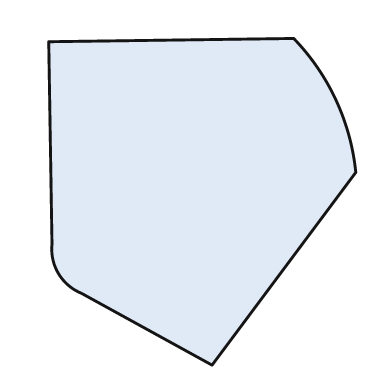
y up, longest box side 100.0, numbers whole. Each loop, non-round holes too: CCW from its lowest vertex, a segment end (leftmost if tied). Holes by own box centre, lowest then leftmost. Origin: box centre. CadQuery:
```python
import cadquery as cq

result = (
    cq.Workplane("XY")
    .moveTo(3.0, -50.0)
    .lineTo(47.0, 9.0)
    .threePointArc((41.0, 31.0), (28.0, 50.0))
    .lineTo(-47.0, 49.0)
    .lineTo(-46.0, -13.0)
    .threePointArc((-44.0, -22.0), (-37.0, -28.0))
    .close()
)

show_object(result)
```